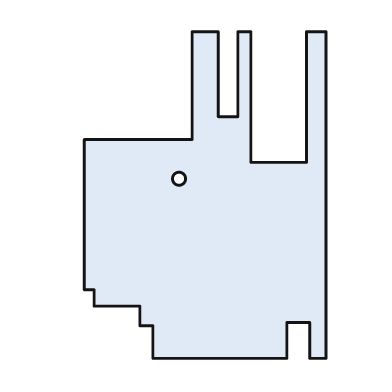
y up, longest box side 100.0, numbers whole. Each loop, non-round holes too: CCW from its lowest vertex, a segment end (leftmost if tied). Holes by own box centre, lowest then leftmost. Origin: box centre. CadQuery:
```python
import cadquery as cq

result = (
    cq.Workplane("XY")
    .moveTo(-16.0, -50.0)
    .lineTo(25.0, -50.0)
    .lineTo(25.0, -39.0)
    .lineTo(32.0, -39.0)
    .lineTo(32.0, -50.0)
    .lineTo(37.0, -50.0)
    .lineTo(37.0, 50.0)
    .lineTo(31.0, 50.0)
    .lineTo(31.0, 10.0)
    .lineTo(14.0, 10.0)
    .lineTo(14.0, 50.0)
    .lineTo(10.0, 50.0)
    .lineTo(10.0, 24.0)
    .lineTo(4.0, 24.0)
    .lineTo(4.0, 50.0)
    .lineTo(-4.0, 50.0)
    .lineTo(-4.0, 17.0)
    .lineTo(-37.0, 17.0)
    .lineTo(-37.0, -29.0)
    .lineTo(-34.0, -29.0)
    .lineTo(-34.0, -34.0)
    .lineTo(-20.0, -34.0)
    .lineTo(-20.0, -40.0)
    .lineTo(-16.0, -40.0)
    .close()
    .moveTo(-8.0, 5.0)
    .circle(2.0)
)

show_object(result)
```